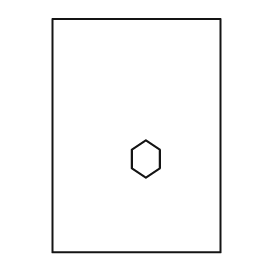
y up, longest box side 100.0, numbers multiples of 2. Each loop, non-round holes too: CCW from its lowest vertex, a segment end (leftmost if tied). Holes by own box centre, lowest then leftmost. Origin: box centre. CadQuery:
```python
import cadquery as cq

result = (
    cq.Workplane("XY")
    .moveTo(-36.0, -50.0)
    .lineTo(36.0, -50.0)
    .lineTo(36.0, 50.0)
    .lineTo(-36.0, 50.0)
    .close()
    .moveTo(4.0, -18.0)
    .lineTo(10.0, -14.0)
    .lineTo(10.0, -6.0)
    .lineTo(4.0, -2.0)
    .lineTo(-2.0, -6.0)
    .lineTo(-2.0, -14.0)
    .close()
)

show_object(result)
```